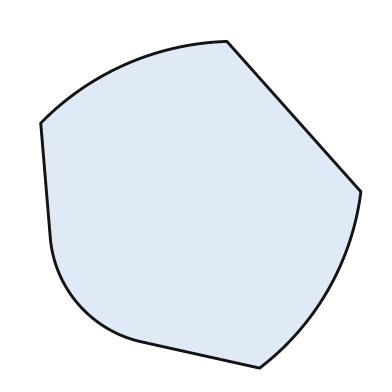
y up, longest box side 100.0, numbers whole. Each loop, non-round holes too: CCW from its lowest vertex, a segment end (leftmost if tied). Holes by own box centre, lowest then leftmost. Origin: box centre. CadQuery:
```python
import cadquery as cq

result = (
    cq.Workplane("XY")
    .moveTo(18.0, -50.0)
    .threePointArc((39.0, -26.0), (49.0, 4.0))
    .lineTo(8.0, 50.0)
    .threePointArc((-23.0, 43.0), (-49.0, 25.0))
    .lineTo(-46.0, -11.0)
    .threePointArc((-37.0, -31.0), (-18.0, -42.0))
    .close()
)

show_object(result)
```